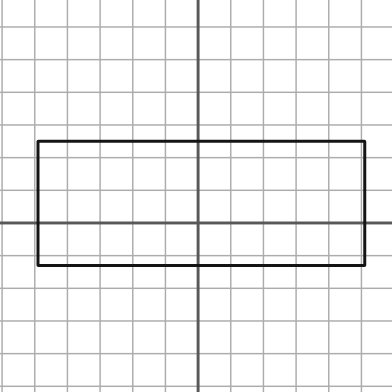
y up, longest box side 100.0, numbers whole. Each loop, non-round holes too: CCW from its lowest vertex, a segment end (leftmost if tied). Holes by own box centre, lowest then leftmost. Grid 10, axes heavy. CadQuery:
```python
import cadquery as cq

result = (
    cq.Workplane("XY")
    .moveTo(-49.0, -13.0)
    .lineTo(51.0, -13.0)
    .lineTo(51.0, 25.0)
    .lineTo(-49.0, 25.0)
    .close()
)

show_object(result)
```